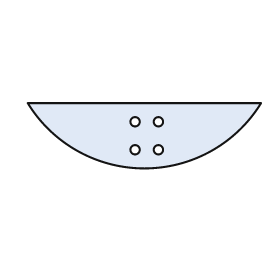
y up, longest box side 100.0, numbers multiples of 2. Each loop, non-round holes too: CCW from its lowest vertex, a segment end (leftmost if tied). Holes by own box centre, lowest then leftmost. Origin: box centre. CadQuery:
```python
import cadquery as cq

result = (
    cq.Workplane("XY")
    .moveTo(-50.0, 14.0)
    .threePointArc((0.0, -14.0), (50.0, 14.0))
    .close()
    .moveTo(-4.0, -6.0)
    .circle(2.0)
    .moveTo(6.0, -6.0)
    .circle(2.0)
    .moveTo(-4.0, 6.0)
    .circle(2.0)
    .moveTo(6.0, 6.0)
    .circle(2.0)
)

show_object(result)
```